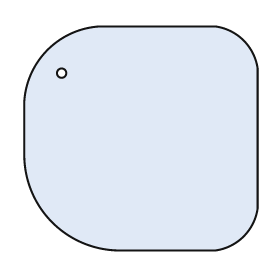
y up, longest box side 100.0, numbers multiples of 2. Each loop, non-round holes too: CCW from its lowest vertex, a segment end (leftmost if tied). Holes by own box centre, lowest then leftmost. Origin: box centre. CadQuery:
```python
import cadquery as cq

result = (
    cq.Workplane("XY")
    .moveTo(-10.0, -48.0)
    .lineTo(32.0, -48.0)
    .threePointArc((44.0, -42.0), (50.0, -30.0))
    .lineTo(50.0, 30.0)
    .threePointArc((44.0, 42.0), (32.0, 48.0))
    .lineTo(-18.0, 48.0)
    .threePointArc((-40.0, 38.0), (-50.0, 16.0))
    .lineTo(-50.0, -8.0)
    .threePointArc((-38.0, -36.0), (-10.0, -48.0))
    .close()
    .moveTo(-34.0, 28.0)
    .circle(2.0)
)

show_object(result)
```